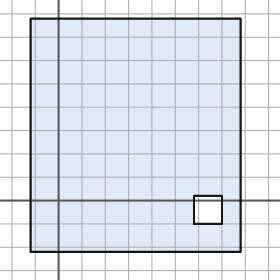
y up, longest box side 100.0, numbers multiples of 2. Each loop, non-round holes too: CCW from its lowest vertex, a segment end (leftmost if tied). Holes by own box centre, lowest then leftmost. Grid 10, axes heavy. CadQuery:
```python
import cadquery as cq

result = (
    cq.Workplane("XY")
    .moveTo(-12.0, -22.0)
    .lineTo(78.0, -22.0)
    .lineTo(78.0, 78.0)
    .lineTo(-12.0, 78.0)
    .close()
    .moveTo(58.0, -10.0)
    .lineTo(70.0, -10.0)
    .lineTo(70.0, 2.0)
    .lineTo(58.0, 2.0)
    .close()
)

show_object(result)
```